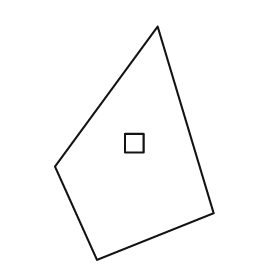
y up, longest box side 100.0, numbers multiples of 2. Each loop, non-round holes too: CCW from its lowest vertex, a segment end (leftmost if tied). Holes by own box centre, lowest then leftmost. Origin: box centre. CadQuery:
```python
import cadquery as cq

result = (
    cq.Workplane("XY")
    .moveTo(-16.0, -50.0)
    .lineTo(34.0, -30.0)
    .lineTo(10.0, 50.0)
    .lineTo(-34.0, -10.0)
    .close()
    .moveTo(-4.0, -4.0)
    .lineTo(4.0, -4.0)
    .lineTo(4.0, 4.0)
    .lineTo(-4.0, 4.0)
    .close()
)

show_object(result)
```